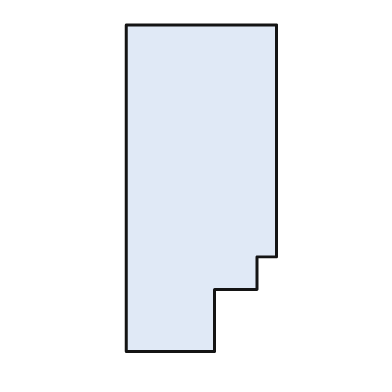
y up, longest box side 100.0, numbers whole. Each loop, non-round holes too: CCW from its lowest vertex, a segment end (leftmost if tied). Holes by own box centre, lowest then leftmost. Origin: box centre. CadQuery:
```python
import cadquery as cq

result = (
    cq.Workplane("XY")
    .moveTo(-23.0, -50.0)
    .lineTo(4.0, -50.0)
    .lineTo(4.0, -31.0)
    .lineTo(17.0, -31.0)
    .lineTo(17.0, -21.0)
    .lineTo(23.0, -21.0)
    .lineTo(23.0, 50.0)
    .lineTo(-23.0, 50.0)
    .close()
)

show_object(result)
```